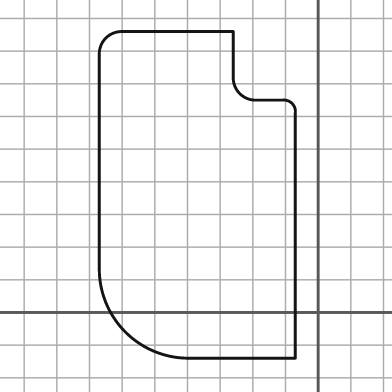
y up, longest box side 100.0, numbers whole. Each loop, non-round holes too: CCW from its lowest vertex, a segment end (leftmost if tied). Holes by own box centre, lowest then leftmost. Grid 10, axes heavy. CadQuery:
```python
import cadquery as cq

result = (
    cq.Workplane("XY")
    .moveTo(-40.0, -14.0)
    .lineTo(-7.0, -14.0)
    .lineTo(-7.0, 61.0)
    .threePointArc((-8.0, 64.0), (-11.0, 65.0))
    .lineTo(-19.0, 65.0)
    .threePointArc((-24.0, 67.0), (-26.0, 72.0))
    .lineTo(-26.0, 86.0)
    .lineTo(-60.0, 86.0)
    .threePointArc((-65.0, 84.0), (-67.0, 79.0))
    .lineTo(-67.0, 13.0)
    .threePointArc((-59.0, -6.0), (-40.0, -14.0))
    .close()
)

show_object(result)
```